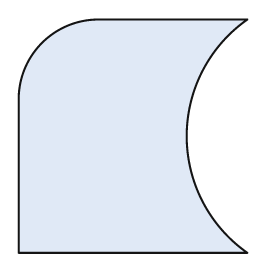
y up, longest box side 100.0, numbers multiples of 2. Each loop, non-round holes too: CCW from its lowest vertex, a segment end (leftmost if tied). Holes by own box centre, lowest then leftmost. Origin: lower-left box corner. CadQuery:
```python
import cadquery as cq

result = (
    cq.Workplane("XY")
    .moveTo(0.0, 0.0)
    .lineTo(98.0, 0.0)
    .threePointArc((72.0, 50.0), (98.0, 100.0))
    .lineTo(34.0, 100.0)
    .threePointArc((10.0, 90.0), (0.0, 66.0))
    .close()
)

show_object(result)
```